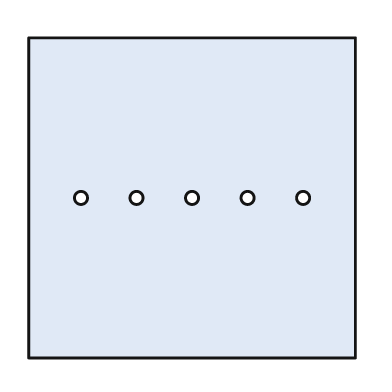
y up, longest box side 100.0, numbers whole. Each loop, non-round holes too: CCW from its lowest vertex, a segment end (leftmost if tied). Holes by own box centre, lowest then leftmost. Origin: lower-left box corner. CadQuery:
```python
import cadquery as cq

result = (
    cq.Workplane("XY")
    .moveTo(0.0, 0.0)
    .lineTo(100.0, 0.0)
    .lineTo(100.0, 98.0)
    .lineTo(0.0, 98.0)
    .close()
    .moveTo(16.0, 49.0)
    .circle(2.0)
    .moveTo(33.0, 49.0)
    .circle(2.0)
    .moveTo(50.0, 49.0)
    .circle(2.0)
    .moveTo(67.0, 49.0)
    .circle(2.0)
    .moveTo(84.0, 49.0)
    .circle(2.0)
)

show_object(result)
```